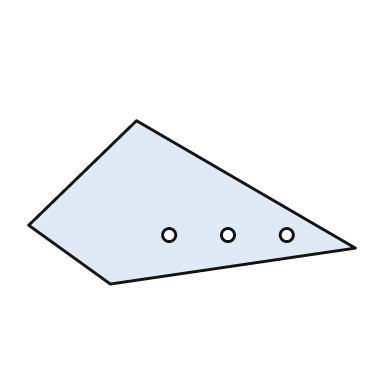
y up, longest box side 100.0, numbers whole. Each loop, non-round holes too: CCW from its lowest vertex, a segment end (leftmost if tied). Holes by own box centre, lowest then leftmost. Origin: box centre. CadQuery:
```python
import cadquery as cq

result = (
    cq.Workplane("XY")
    .moveTo(-25.0, -25.0)
    .lineTo(50.0, -14.0)
    .lineTo(-17.0, 25.0)
    .lineTo(-50.0, -7.0)
    .close()
    .moveTo(-7.0, -10.0)
    .circle(2.0)
    .moveTo(11.0, -10.0)
    .circle(2.0)
    .moveTo(29.0, -10.0)
    .circle(2.0)
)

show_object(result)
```